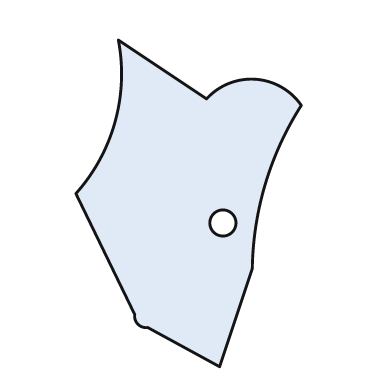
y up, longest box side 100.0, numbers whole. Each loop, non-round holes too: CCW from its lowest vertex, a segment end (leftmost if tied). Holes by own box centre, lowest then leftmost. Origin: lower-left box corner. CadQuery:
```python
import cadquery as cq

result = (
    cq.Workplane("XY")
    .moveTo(44.0, 0.0)
    .lineTo(54.0, 30.0)
    .threePointArc((58.0, 56.0), (69.0, 80.0))
    .threePointArc((55.0, 88.0), (40.0, 82.0))
    .lineTo(13.0, 100.0)
    .threePointArc((12.0, 75.0), (0.0, 53.0))
    .lineTo(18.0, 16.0)
    .threePointArc((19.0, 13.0), (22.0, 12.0))
    .close()
    .moveTo(45.0, 44.0)
    .circle(4.0)
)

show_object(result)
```